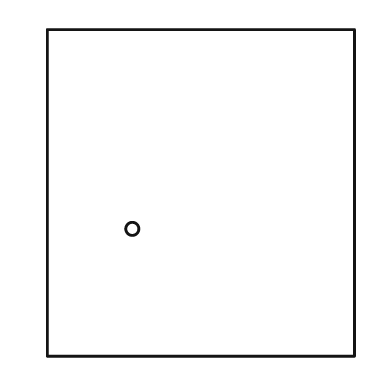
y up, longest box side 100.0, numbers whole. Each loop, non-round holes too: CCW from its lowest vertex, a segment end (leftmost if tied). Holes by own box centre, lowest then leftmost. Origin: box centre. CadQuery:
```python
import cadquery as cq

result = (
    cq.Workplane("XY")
    .moveTo(-47.0, -50.0)
    .lineTo(47.0, -50.0)
    .lineTo(47.0, 50.0)
    .lineTo(-47.0, 50.0)
    .close()
    .moveTo(-21.0, -11.0)
    .circle(2.0)
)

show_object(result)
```